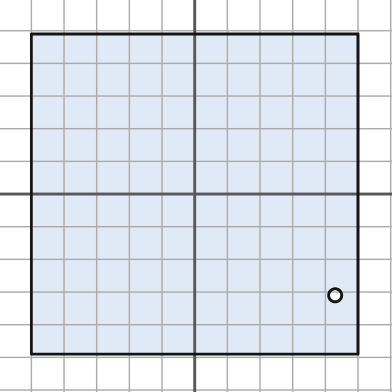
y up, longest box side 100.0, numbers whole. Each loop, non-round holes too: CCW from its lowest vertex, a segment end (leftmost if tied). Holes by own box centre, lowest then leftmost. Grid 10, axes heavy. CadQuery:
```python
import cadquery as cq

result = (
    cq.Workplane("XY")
    .moveTo(-50.0, -49.0)
    .lineTo(50.0, -49.0)
    .lineTo(50.0, 49.0)
    .lineTo(-50.0, 49.0)
    .close()
    .moveTo(43.0, -31.0)
    .circle(2.0)
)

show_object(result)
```